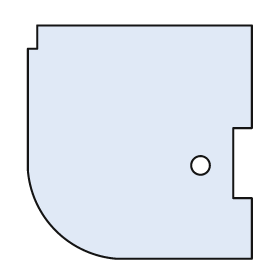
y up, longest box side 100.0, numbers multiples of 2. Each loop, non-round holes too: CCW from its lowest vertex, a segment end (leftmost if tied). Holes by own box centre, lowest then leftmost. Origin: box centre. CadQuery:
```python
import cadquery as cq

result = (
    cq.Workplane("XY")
    .moveTo(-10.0, -50.0)
    .lineTo(48.0, -50.0)
    .lineTo(48.0, -24.0)
    .lineTo(40.0, -24.0)
    .lineTo(40.0, 6.0)
    .lineTo(48.0, 6.0)
    .lineTo(48.0, 50.0)
    .lineTo(-44.0, 50.0)
    .lineTo(-44.0, 40.0)
    .lineTo(-48.0, 40.0)
    .lineTo(-48.0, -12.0)
    .threePointArc((-36.0, -38.0), (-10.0, -50.0))
    .close()
    .moveTo(26.0, -10.0)
    .circle(4.0)
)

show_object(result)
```